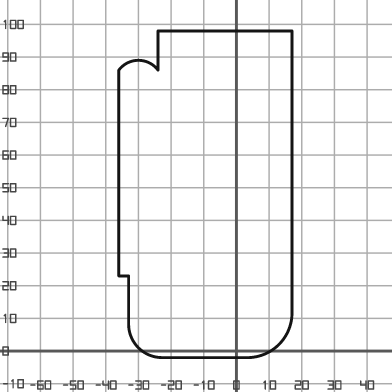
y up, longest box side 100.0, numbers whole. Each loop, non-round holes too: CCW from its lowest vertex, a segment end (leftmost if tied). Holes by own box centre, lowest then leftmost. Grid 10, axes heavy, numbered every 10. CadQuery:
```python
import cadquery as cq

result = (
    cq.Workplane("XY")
    .moveTo(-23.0, -2.0)
    .lineTo(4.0, -2.0)
    .threePointArc((13.0, 2.0), (17.0, 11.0))
    .lineTo(17.0, 98.0)
    .lineTo(-24.0, 98.0)
    .lineTo(-24.0, 86.0)
    .threePointArc((-30.0, 89.0), (-36.0, 86.0))
    .lineTo(-36.0, 23.0)
    .lineTo(-33.0, 23.0)
    .lineTo(-33.0, 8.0)
    .threePointArc((-30.0, 1.0), (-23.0, -2.0))
    .close()
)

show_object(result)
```